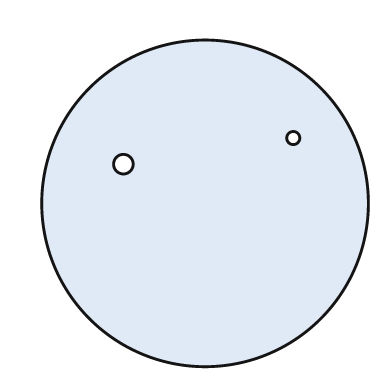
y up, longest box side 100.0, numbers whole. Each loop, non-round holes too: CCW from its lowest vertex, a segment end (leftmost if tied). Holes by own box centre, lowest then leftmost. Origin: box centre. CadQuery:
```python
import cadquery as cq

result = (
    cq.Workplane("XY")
    .moveTo(0.0, 0.0)
    .circle(50.0)
    .moveTo(-25.0, 12.0)
    .circle(3.0)
    .moveTo(27.0, 20.0)
    .circle(2.0)
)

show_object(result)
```